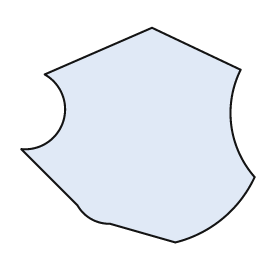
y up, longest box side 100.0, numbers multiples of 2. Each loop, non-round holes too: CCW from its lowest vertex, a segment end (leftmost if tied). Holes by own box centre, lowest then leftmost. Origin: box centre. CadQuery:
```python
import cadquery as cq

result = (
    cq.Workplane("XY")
    .moveTo(16.0, -46.0)
    .threePointArc((36.0, -36.0), (50.0, -18.0))
    .threePointArc((40.0, 4.0), (44.0, 28.0))
    .lineTo(6.0, 46.0)
    .lineTo(-40.0, 26.0)
    .threePointArc((-32.0, 6.0), (-50.0, -6.0))
    .lineTo(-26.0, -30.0)
    .threePointArc((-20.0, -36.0), (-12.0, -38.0))
    .close()
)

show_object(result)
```